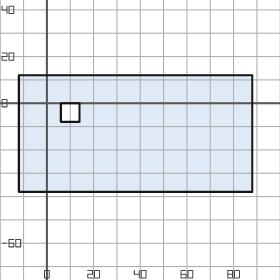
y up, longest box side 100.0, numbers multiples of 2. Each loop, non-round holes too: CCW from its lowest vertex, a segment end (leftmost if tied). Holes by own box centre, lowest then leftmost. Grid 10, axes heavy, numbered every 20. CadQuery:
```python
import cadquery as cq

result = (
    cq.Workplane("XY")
    .moveTo(-12.0, -38.0)
    .lineTo(88.0, -38.0)
    .lineTo(88.0, 12.0)
    .lineTo(-12.0, 12.0)
    .close()
    .moveTo(6.0, -8.0)
    .lineTo(14.0, -8.0)
    .lineTo(14.0, 0.0)
    .lineTo(6.0, 0.0)
    .close()
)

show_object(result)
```